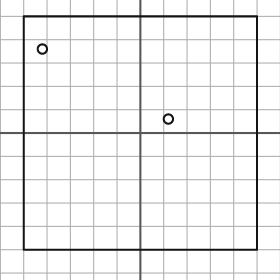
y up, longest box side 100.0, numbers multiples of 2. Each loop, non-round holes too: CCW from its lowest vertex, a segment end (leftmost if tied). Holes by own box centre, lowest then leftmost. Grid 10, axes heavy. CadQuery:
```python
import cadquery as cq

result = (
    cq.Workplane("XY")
    .moveTo(-50.0, -50.0)
    .lineTo(50.0, -50.0)
    .lineTo(50.0, 50.0)
    .lineTo(-50.0, 50.0)
    .close()
    .moveTo(12.0, 6.0)
    .circle(2.0)
    .moveTo(-42.0, 36.0)
    .circle(2.0)
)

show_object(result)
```